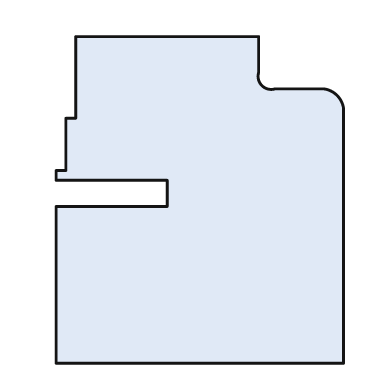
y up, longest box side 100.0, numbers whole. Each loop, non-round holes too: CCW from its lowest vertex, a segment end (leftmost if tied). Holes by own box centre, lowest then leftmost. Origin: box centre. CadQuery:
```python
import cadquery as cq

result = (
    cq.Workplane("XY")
    .moveTo(-44.0, -50.0)
    .lineTo(44.0, -50.0)
    .lineTo(44.0, 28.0)
    .threePointArc((42.0, 32.0), (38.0, 34.0))
    .lineTo(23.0, 34.0)
    .threePointArc((19.0, 35.0), (18.0, 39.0))
    .lineTo(18.0, 50.0)
    .lineTo(-38.0, 50.0)
    .lineTo(-38.0, 25.0)
    .lineTo(-41.0, 25.0)
    .lineTo(-41.0, 9.0)
    .lineTo(-44.0, 9.0)
    .lineTo(-44.0, 6.0)
    .lineTo(-10.0, 6.0)
    .lineTo(-10.0, -2.0)
    .lineTo(-44.0, -2.0)
    .close()
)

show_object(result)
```